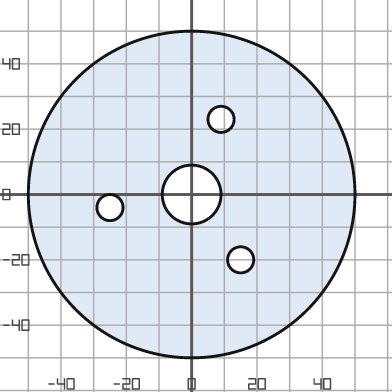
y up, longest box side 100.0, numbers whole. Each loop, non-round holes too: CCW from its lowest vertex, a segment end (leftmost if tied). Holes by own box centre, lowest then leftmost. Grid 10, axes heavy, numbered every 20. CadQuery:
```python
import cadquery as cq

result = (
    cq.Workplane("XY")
    .moveTo(0.0, 0.0)
    .circle(50.0)
    .moveTo(15.0, -20.0)
    .circle(4.0)
    .moveTo(-25.0, -4.0)
    .circle(4.0)
    .moveTo(0.0, 0.0)
    .circle(9.0)
    .moveTo(9.0, 23.0)
    .circle(4.0)
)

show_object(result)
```